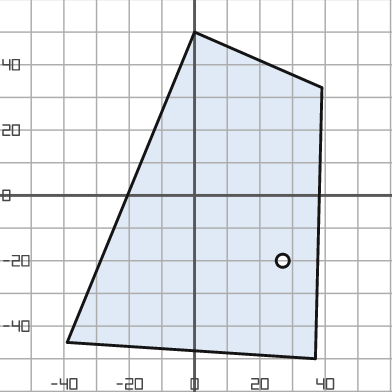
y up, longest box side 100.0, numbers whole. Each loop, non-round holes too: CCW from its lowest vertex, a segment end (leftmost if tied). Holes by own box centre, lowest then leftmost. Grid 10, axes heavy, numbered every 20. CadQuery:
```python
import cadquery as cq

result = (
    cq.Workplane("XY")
    .moveTo(37.0, -50.0)
    .lineTo(39.0, 33.0)
    .lineTo(0.0, 50.0)
    .lineTo(-39.0, -45.0)
    .close()
    .moveTo(27.0, -20.0)
    .circle(2.0)
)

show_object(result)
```